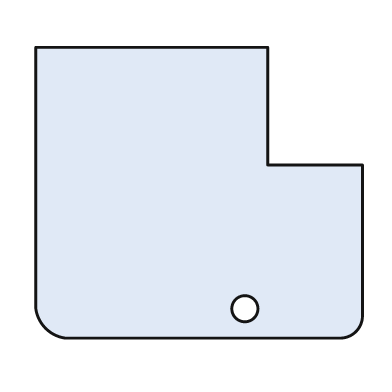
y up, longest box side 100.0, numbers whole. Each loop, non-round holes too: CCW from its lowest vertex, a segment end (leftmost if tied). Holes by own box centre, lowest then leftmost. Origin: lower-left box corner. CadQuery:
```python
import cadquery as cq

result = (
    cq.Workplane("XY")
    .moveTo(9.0, 0.0)
    .lineTo(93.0, 0.0)
    .threePointArc((98.0, 2.0), (100.0, 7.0))
    .lineTo(100.0, 53.0)
    .lineTo(71.0, 53.0)
    .lineTo(71.0, 89.0)
    .lineTo(0.0, 89.0)
    .lineTo(0.0, 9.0)
    .threePointArc((3.0, 3.0), (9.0, 0.0))
    .close()
    .moveTo(64.0, 9.0)
    .circle(4.0)
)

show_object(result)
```